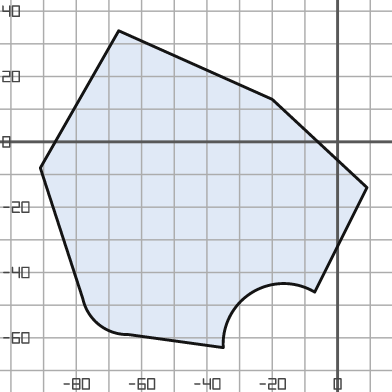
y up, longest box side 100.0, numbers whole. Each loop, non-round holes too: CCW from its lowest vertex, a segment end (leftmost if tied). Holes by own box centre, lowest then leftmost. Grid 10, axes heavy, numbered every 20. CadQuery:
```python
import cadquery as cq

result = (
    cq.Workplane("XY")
    .moveTo(-35.0, -63.0)
    .threePointArc((-26.0, -46.0), (-7.0, -46.0))
    .lineTo(9.0, -14.0)
    .lineTo(-20.0, 13.0)
    .lineTo(-67.0, 34.0)
    .lineTo(-91.0, -8.0)
    .lineTo(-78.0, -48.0)
    .threePointArc((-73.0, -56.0), (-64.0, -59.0))
    .close()
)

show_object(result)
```